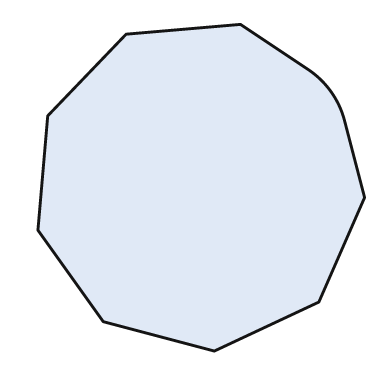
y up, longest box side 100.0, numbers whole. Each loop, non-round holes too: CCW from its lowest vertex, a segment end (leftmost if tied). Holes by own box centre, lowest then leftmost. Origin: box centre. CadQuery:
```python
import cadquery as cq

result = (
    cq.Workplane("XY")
    .moveTo(4.0, -50.0)
    .lineTo(36.0, -35.0)
    .lineTo(50.0, -3.0)
    .lineTo(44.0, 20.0)
    .threePointArc((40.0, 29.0), (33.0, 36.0))
    .lineTo(12.0, 50.0)
    .lineTo(-23.0, 47.0)
    .lineTo(-47.0, 22.0)
    .lineTo(-50.0, -13.0)
    .lineTo(-30.0, -41.0)
    .close()
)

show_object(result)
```